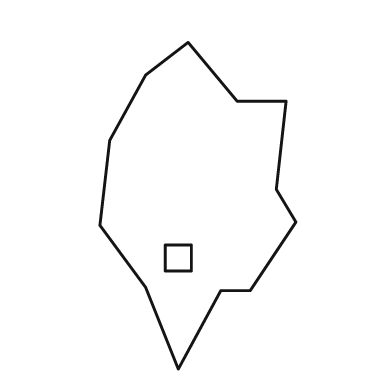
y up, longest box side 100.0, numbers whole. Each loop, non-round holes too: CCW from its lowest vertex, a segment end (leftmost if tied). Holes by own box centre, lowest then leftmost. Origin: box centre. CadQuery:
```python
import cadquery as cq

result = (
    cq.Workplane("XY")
    .moveTo(-6.0, -50.0)
    .lineTo(7.0, -26.0)
    .lineTo(16.0, -26.0)
    .lineTo(30.0, -5.0)
    .lineTo(24.0, 5.0)
    .lineTo(27.0, 32.0)
    .lineTo(12.0, 32.0)
    .lineTo(-3.0, 50.0)
    .lineTo(-16.0, 40.0)
    .lineTo(-27.0, 20.0)
    .lineTo(-30.0, -6.0)
    .lineTo(-16.0, -25.0)
    .close()
    .moveTo(-10.0, -20.0)
    .lineTo(-2.0, -20.0)
    .lineTo(-2.0, -12.0)
    .lineTo(-10.0, -12.0)
    .close()
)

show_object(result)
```